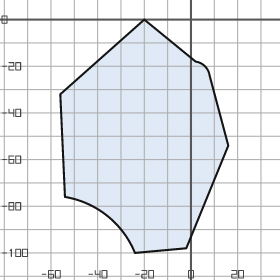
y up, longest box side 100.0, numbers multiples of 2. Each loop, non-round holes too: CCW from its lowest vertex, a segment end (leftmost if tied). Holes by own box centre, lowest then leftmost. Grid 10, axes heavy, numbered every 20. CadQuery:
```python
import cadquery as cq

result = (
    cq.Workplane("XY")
    .moveTo(-24.0, -100.0)
    .lineTo(-2.0, -98.0)
    .lineTo(16.0, -54.0)
    .lineTo(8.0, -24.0)
    .threePointArc((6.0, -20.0), (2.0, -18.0))
    .lineTo(-20.0, 0.0)
    .lineTo(-56.0, -32.0)
    .lineTo(-54.0, -76.0)
    .threePointArc((-36.0, -84.0), (-24.0, -100.0))
    .close()
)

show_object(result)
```